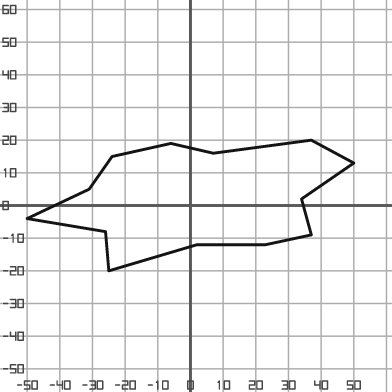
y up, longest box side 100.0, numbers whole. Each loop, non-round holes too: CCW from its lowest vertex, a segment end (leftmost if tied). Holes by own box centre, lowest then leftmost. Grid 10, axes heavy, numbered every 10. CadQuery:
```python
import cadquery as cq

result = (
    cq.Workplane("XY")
    .moveTo(-25.0, -20.0)
    .lineTo(2.0, -12.0)
    .lineTo(23.0, -12.0)
    .lineTo(37.0, -9.0)
    .lineTo(34.0, 2.0)
    .lineTo(50.0, 13.0)
    .lineTo(37.0, 20.0)
    .lineTo(7.0, 16.0)
    .lineTo(-6.0, 19.0)
    .lineTo(-24.0, 15.0)
    .lineTo(-31.0, 5.0)
    .lineTo(-50.0, -4.0)
    .lineTo(-26.0, -8.0)
    .close()
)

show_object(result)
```